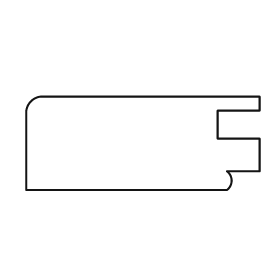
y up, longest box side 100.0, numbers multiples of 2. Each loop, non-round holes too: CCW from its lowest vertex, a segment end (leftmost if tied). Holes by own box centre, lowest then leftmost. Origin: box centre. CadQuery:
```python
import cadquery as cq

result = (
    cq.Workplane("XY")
    .moveTo(-50.0, -20.0)
    .lineTo(36.0, -20.0)
    .threePointArc((38.0, -16.0), (36.0, -12.0))
    .lineTo(50.0, -12.0)
    .lineTo(50.0, 2.0)
    .lineTo(32.0, 2.0)
    .lineTo(32.0, 14.0)
    .lineTo(50.0, 14.0)
    .lineTo(50.0, 20.0)
    .lineTo(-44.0, 20.0)
    .threePointArc((-48.0, 18.0), (-50.0, 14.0))
    .close()
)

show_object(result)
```